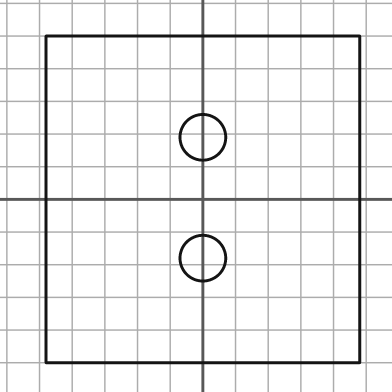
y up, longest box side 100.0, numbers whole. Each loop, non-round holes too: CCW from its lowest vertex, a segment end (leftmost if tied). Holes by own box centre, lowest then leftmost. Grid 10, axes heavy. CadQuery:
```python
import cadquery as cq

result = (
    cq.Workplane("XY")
    .moveTo(-48.0, -50.0)
    .lineTo(48.0, -50.0)
    .lineTo(48.0, 50.0)
    .lineTo(-48.0, 50.0)
    .close()
    .moveTo(0.0, -18.0)
    .circle(7.0)
    .moveTo(0.0, 19.0)
    .circle(7.0)
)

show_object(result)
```